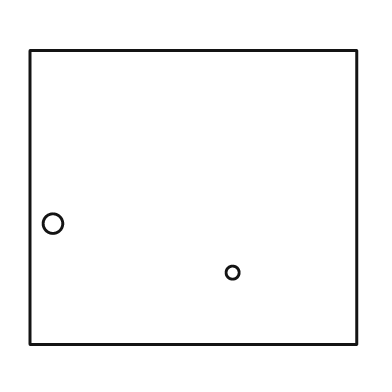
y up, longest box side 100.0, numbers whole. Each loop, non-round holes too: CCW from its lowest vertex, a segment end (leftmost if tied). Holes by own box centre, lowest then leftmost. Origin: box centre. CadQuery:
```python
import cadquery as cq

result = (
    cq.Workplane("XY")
    .moveTo(-50.0, -45.0)
    .lineTo(50.0, -45.0)
    .lineTo(50.0, 45.0)
    .lineTo(-50.0, 45.0)
    .close()
    .moveTo(12.0, -23.0)
    .circle(2.0)
    .moveTo(-43.0, -8.0)
    .circle(3.0)
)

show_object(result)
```